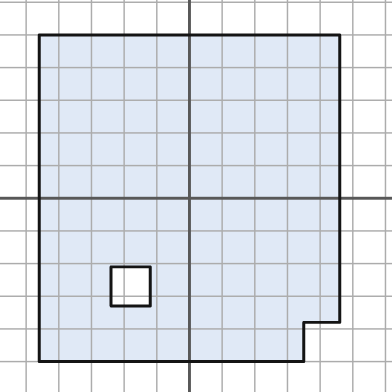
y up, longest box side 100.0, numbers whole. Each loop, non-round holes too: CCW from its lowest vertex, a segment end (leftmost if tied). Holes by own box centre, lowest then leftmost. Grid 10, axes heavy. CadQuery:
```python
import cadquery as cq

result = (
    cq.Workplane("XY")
    .moveTo(-46.0, -50.0)
    .lineTo(35.0, -50.0)
    .lineTo(35.0, -38.0)
    .lineTo(46.0, -38.0)
    .lineTo(46.0, 50.0)
    .lineTo(-46.0, 50.0)
    .close()
    .moveTo(-24.0, -33.0)
    .lineTo(-12.0, -33.0)
    .lineTo(-12.0, -21.0)
    .lineTo(-24.0, -21.0)
    .close()
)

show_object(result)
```